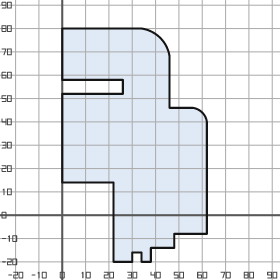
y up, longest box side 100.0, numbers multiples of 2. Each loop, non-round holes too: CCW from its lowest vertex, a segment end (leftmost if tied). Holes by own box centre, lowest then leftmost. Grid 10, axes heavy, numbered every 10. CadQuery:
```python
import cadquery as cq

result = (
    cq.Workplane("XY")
    .moveTo(22.0, -20.0)
    .lineTo(30.0, -20.0)
    .lineTo(30.0, -16.0)
    .lineTo(34.0, -16.0)
    .lineTo(34.0, -20.0)
    .lineTo(38.0, -20.0)
    .lineTo(38.0, -14.0)
    .lineTo(48.0, -14.0)
    .lineTo(48.0, -8.0)
    .lineTo(62.0, -8.0)
    .lineTo(62.0, 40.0)
    .threePointArc((60.0, 44.0), (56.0, 46.0))
    .lineTo(46.0, 46.0)
    .lineTo(46.0, 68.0)
    .threePointArc((42.0, 76.0), (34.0, 80.0))
    .lineTo(0.0, 80.0)
    .lineTo(0.0, 58.0)
    .lineTo(26.0, 58.0)
    .lineTo(26.0, 52.0)
    .lineTo(0.0, 52.0)
    .lineTo(0.0, 14.0)
    .lineTo(22.0, 14.0)
    .close()
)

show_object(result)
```